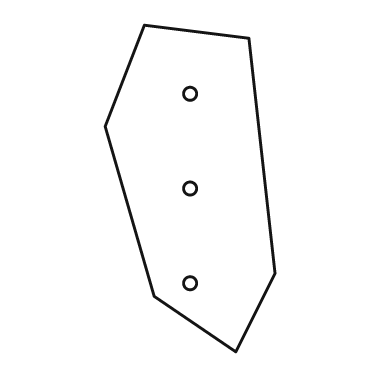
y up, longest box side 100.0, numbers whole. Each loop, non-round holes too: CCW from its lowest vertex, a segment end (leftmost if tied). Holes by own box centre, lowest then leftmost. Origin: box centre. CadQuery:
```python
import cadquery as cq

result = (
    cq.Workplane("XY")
    .moveTo(14.0, -50.0)
    .lineTo(26.0, -26.0)
    .lineTo(18.0, 46.0)
    .lineTo(-14.0, 50.0)
    .lineTo(-26.0, 19.0)
    .lineTo(-11.0, -33.0)
    .close()
    .moveTo(0.0, -29.0)
    .circle(2.0)
    .moveTo(0.0, 0.0)
    .circle(2.0)
    .moveTo(0.0, 29.0)
    .circle(2.0)
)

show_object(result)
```